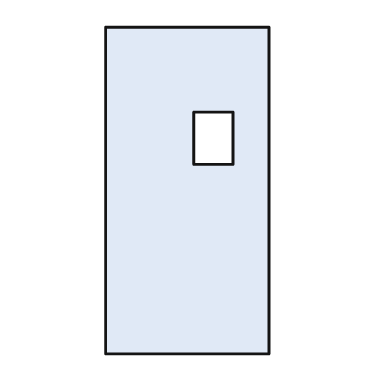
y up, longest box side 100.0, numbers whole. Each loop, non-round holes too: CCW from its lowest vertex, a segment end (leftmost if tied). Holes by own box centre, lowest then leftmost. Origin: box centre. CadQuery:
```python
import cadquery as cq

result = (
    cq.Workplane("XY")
    .moveTo(-25.0, -50.0)
    .lineTo(25.0, -50.0)
    .lineTo(25.0, 50.0)
    .lineTo(-25.0, 50.0)
    .close()
    .moveTo(2.0, 8.0)
    .lineTo(14.0, 8.0)
    .lineTo(14.0, 24.0)
    .lineTo(2.0, 24.0)
    .close()
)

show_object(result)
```